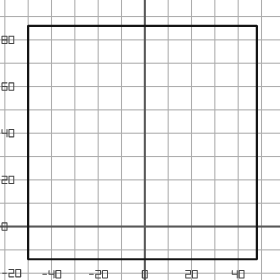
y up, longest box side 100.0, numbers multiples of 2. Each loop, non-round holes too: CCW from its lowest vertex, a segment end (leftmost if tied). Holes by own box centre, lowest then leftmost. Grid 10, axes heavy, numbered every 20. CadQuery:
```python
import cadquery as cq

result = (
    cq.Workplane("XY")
    .moveTo(-50.0, -14.0)
    .lineTo(48.0, -14.0)
    .lineTo(48.0, 86.0)
    .lineTo(-50.0, 86.0)
    .close()
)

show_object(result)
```